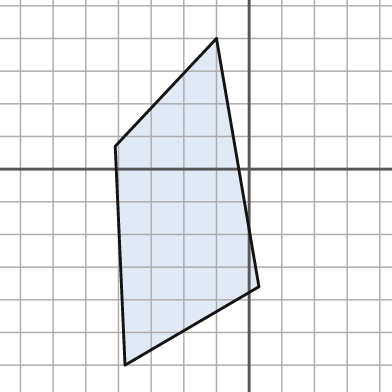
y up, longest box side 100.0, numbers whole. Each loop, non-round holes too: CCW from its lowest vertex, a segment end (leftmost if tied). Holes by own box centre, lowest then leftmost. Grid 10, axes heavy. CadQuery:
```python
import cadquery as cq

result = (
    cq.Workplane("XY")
    .moveTo(-38.0, -60.0)
    .lineTo(3.0, -36.0)
    .lineTo(-10.0, 40.0)
    .lineTo(-41.0, 7.0)
    .close()
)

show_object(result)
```